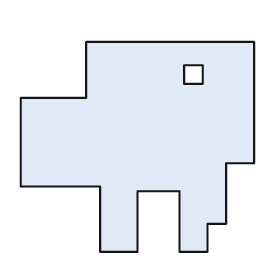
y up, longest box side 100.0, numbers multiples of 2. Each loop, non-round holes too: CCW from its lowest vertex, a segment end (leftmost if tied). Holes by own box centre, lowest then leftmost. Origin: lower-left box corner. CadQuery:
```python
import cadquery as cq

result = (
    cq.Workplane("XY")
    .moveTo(34.0, 0.0)
    .lineTo(50.0, 0.0)
    .lineTo(50.0, 26.0)
    .lineTo(68.0, 26.0)
    .lineTo(68.0, 0.0)
    .lineTo(80.0, 0.0)
    .lineTo(80.0, 12.0)
    .lineTo(88.0, 12.0)
    .lineTo(88.0, 38.0)
    .lineTo(100.0, 38.0)
    .lineTo(100.0, 90.0)
    .lineTo(28.0, 90.0)
    .lineTo(28.0, 66.0)
    .lineTo(0.0, 66.0)
    .lineTo(0.0, 28.0)
    .lineTo(34.0, 28.0)
    .close()
    .moveTo(70.0, 72.0)
    .lineTo(78.0, 72.0)
    .lineTo(78.0, 80.0)
    .lineTo(70.0, 80.0)
    .close()
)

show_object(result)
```